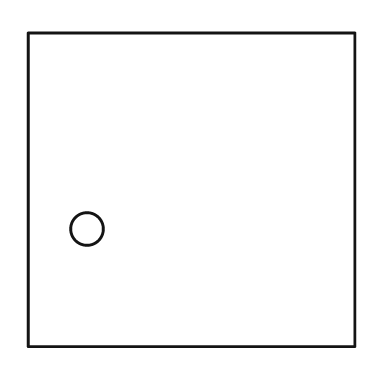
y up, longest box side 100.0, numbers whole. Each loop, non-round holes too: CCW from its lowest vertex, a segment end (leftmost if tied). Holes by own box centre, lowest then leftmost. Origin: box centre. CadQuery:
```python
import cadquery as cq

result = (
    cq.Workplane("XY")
    .moveTo(-50.0, -48.0)
    .lineTo(50.0, -48.0)
    .lineTo(50.0, 48.0)
    .lineTo(-50.0, 48.0)
    .close()
    .moveTo(-32.0, -12.0)
    .circle(5.0)
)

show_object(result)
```